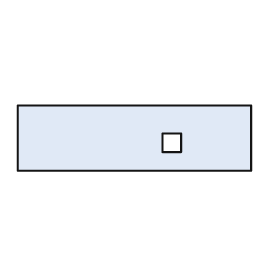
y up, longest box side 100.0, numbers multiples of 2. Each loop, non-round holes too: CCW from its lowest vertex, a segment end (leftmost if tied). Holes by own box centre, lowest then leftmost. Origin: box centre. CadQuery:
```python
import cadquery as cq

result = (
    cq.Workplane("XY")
    .moveTo(-50.0, -14.0)
    .lineTo(50.0, -14.0)
    .lineTo(50.0, 14.0)
    .lineTo(-50.0, 14.0)
    .close()
    .moveTo(12.0, -6.0)
    .lineTo(20.0, -6.0)
    .lineTo(20.0, 2.0)
    .lineTo(12.0, 2.0)
    .close()
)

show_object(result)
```